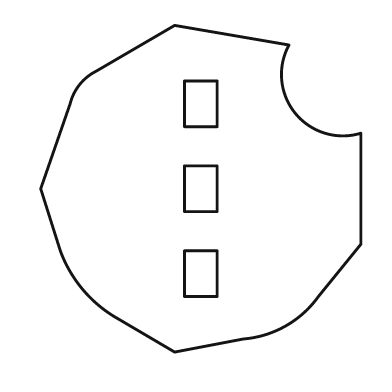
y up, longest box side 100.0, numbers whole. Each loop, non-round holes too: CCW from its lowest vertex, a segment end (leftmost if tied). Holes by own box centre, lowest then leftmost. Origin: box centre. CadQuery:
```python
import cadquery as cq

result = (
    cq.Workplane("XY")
    .moveTo(-8.0, -50.0)
    .lineTo(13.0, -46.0)
    .threePointArc((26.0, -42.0), (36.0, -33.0))
    .lineTo(49.0, -17.0)
    .lineTo(49.0, 17.0)
    .threePointArc((29.0, 23.0), (27.0, 44.0))
    .lineTo(-8.0, 50.0)
    .lineTo(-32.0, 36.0)
    .threePointArc((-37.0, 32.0), (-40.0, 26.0))
    .lineTo(-49.0, 0.0)
    .lineTo(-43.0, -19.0)
    .threePointArc((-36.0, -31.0), (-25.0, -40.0))
    .close()
    .moveTo(-5.0, -33.0)
    .lineTo(5.0, -33.0)
    .lineTo(5.0, -19.0)
    .lineTo(-5.0, -19.0)
    .close()
    .moveTo(-5.0, -7.0)
    .lineTo(5.0, -7.0)
    .lineTo(5.0, 7.0)
    .lineTo(-5.0, 7.0)
    .close()
    .moveTo(-5.0, 19.0)
    .lineTo(5.0, 19.0)
    .lineTo(5.0, 33.0)
    .lineTo(-5.0, 33.0)
    .close()
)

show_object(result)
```